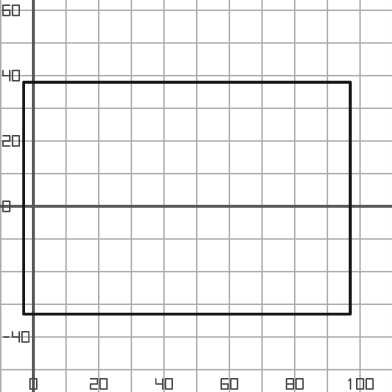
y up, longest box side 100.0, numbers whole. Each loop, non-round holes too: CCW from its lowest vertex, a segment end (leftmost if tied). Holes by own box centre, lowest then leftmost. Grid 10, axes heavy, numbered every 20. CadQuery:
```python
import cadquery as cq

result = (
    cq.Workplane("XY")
    .moveTo(-3.0, -33.0)
    .lineTo(97.0, -33.0)
    .lineTo(97.0, 38.0)
    .lineTo(-3.0, 38.0)
    .close()
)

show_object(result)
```